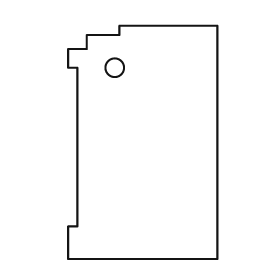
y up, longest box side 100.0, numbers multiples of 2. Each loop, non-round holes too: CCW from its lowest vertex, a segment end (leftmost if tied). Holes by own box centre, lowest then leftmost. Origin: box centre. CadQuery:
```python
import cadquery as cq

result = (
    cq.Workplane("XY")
    .moveTo(-32.0, -50.0)
    .lineTo(32.0, -50.0)
    .lineTo(32.0, 50.0)
    .lineTo(-10.0, 50.0)
    .lineTo(-10.0, 46.0)
    .lineTo(-24.0, 46.0)
    .lineTo(-24.0, 40.0)
    .lineTo(-32.0, 40.0)
    .lineTo(-32.0, 32.0)
    .lineTo(-28.0, 32.0)
    .lineTo(-28.0, -36.0)
    .lineTo(-32.0, -36.0)
    .close()
    .moveTo(-12.0, 32.0)
    .circle(4.0)
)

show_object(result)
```